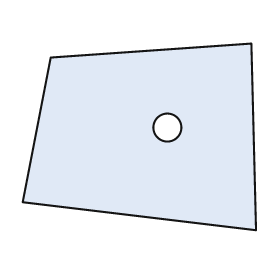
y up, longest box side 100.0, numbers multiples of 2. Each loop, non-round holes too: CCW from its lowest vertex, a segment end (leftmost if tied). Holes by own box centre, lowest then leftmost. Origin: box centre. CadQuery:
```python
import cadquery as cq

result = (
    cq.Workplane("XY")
    .moveTo(50.0, -40.0)
    .lineTo(48.0, 40.0)
    .lineTo(-38.0, 34.0)
    .lineTo(-50.0, -28.0)
    .close()
    .moveTo(12.0, 4.0)
    .circle(6.0)
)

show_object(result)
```